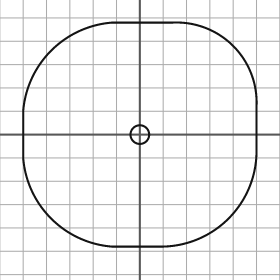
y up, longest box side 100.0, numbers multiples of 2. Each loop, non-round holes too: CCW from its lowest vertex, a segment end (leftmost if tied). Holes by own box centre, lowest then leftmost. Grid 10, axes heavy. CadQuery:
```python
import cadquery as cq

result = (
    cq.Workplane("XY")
    .moveTo(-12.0, -48.0)
    .lineTo(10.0, -48.0)
    .threePointArc((38.0, -36.0), (50.0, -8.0))
    .lineTo(50.0, 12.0)
    .threePointArc((40.0, 38.0), (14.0, 48.0))
    .lineTo(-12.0, 48.0)
    .threePointArc((-38.0, 36.0), (-50.0, 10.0))
    .lineTo(-50.0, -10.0)
    .threePointArc((-38.0, -36.0), (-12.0, -48.0))
    .close()
    .moveTo(0.0, 0.0)
    .circle(4.0)
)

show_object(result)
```